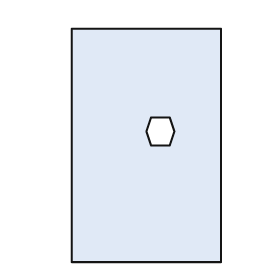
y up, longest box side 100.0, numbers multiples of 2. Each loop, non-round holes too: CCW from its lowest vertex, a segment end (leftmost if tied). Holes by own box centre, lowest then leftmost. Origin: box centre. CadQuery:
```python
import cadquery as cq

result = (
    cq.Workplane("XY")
    .moveTo(-32.0, -50.0)
    .lineTo(32.0, -50.0)
    .lineTo(32.0, 50.0)
    .lineTo(-32.0, 50.0)
    .close()
    .moveTo(2.0, 0.0)
    .lineTo(10.0, 0.0)
    .lineTo(12.0, 6.0)
    .lineTo(10.0, 12.0)
    .lineTo(2.0, 12.0)
    .lineTo(0.0, 6.0)
    .close()
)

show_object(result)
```